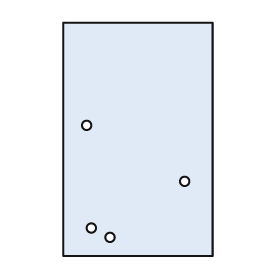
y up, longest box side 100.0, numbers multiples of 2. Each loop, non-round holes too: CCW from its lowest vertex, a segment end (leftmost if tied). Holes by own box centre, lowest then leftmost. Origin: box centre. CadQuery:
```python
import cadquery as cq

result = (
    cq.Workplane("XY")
    .moveTo(-32.0, -50.0)
    .lineTo(32.0, -50.0)
    .lineTo(32.0, 50.0)
    .lineTo(-32.0, 50.0)
    .close()
    .moveTo(-12.0, -42.0)
    .circle(2.0)
    .moveTo(-20.0, -38.0)
    .circle(2.0)
    .moveTo(20.0, -18.0)
    .circle(2.0)
    .moveTo(-22.0, 6.0)
    .circle(2.0)
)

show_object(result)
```